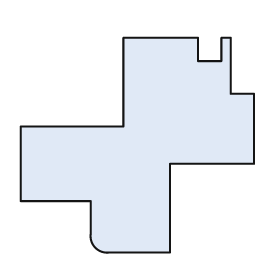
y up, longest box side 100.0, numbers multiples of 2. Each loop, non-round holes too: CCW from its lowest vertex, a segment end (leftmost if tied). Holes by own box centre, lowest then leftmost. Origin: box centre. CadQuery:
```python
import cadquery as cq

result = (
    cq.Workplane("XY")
    .moveTo(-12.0, -46.0)
    .lineTo(14.0, -46.0)
    .lineTo(14.0, -8.0)
    .lineTo(50.0, -8.0)
    .lineTo(50.0, 22.0)
    .lineTo(40.0, 22.0)
    .lineTo(40.0, 46.0)
    .lineTo(36.0, 46.0)
    .lineTo(36.0, 36.0)
    .lineTo(26.0, 36.0)
    .lineTo(26.0, 46.0)
    .lineTo(-6.0, 46.0)
    .lineTo(-6.0, 8.0)
    .lineTo(-50.0, 8.0)
    .lineTo(-50.0, -24.0)
    .lineTo(-20.0, -24.0)
    .lineTo(-20.0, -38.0)
    .threePointArc((-18.0, -44.0), (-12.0, -46.0))
    .close()
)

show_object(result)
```